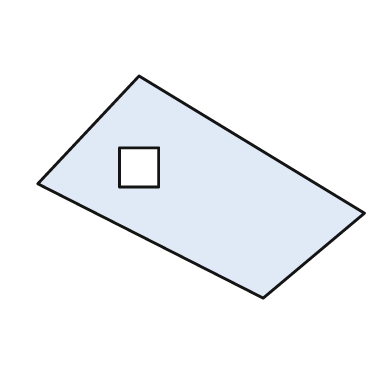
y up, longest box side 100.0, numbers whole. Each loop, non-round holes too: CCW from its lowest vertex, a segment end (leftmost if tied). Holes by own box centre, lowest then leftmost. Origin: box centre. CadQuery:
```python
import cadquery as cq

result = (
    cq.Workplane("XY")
    .moveTo(19.0, -34.0)
    .lineTo(50.0, -8.0)
    .lineTo(-19.0, 34.0)
    .lineTo(-50.0, 1.0)
    .close()
    .moveTo(-25.0, 0.0)
    .lineTo(-13.0, 0.0)
    .lineTo(-13.0, 12.0)
    .lineTo(-25.0, 12.0)
    .close()
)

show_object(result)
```